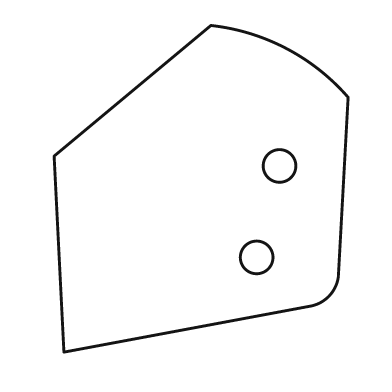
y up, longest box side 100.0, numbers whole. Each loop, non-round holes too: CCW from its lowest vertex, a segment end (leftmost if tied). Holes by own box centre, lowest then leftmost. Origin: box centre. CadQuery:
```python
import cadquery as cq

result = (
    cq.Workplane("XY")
    .moveTo(-42.0, -50.0)
    .lineTo(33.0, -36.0)
    .threePointArc((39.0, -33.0), (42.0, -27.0))
    .lineTo(45.0, 28.0)
    .threePointArc((26.0, 43.0), (3.0, 50.0))
    .lineTo(-45.0, 10.0)
    .close()
    .moveTo(17.0, -21.0)
    .circle(5.0)
    .moveTo(24.0, 7.0)
    .circle(5.0)
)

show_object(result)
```